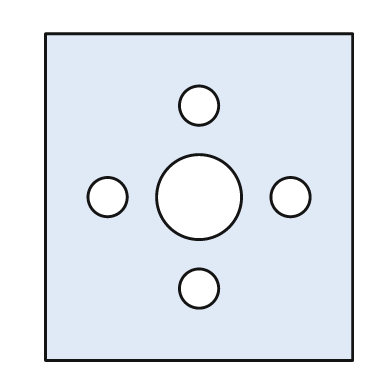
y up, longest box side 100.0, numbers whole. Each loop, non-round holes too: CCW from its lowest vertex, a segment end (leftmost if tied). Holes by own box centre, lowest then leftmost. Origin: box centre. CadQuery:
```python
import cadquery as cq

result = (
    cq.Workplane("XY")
    .moveTo(-47.0, -50.0)
    .lineTo(47.0, -50.0)
    .lineTo(47.0, 50.0)
    .lineTo(-47.0, 50.0)
    .close()
    .moveTo(0.0, -28.0)
    .circle(6.0)
    .moveTo(-28.0, 0.0)
    .circle(6.0)
    .moveTo(0.0, 0.0)
    .circle(13.0)
    .moveTo(28.0, 0.0)
    .circle(6.0)
    .moveTo(0.0, 28.0)
    .circle(6.0)
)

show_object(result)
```